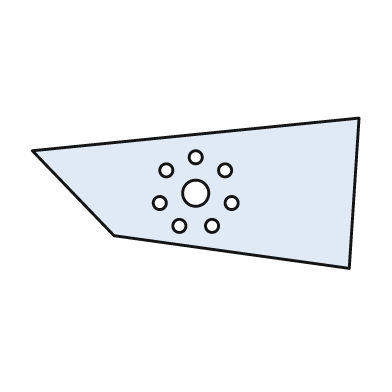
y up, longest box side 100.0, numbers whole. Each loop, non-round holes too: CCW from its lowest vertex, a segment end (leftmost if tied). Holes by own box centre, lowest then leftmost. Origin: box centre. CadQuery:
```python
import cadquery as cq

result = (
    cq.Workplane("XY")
    .moveTo(47.0, -23.0)
    .lineTo(50.0, 23.0)
    .lineTo(-50.0, 13.0)
    .lineTo(-25.0, -13.0)
    .close()
    .moveTo(-5.0, -10.0)
    .circle(2.0)
    .moveTo(5.0, -10.0)
    .circle(2.0)
    .moveTo(-11.0, -3.0)
    .circle(2.0)
    .moveTo(11.0, -3.0)
    .circle(2.0)
    .moveTo(0.0, 0.0)
    .circle(4.0)
    .moveTo(-9.0, 7.0)
    .circle(2.0)
    .moveTo(9.0, 7.0)
    .circle(2.0)
    .moveTo(0.0, 11.0)
    .circle(2.0)
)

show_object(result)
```